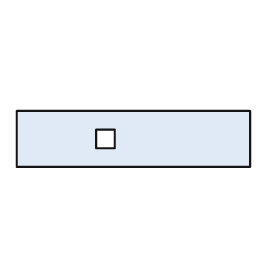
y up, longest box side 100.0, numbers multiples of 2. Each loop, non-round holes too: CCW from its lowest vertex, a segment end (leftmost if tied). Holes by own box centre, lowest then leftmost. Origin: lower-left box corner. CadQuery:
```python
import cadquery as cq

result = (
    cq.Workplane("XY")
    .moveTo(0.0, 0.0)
    .lineTo(100.0, 0.0)
    .lineTo(100.0, 24.0)
    .lineTo(0.0, 24.0)
    .close()
    .moveTo(34.0, 8.0)
    .lineTo(42.0, 8.0)
    .lineTo(42.0, 16.0)
    .lineTo(34.0, 16.0)
    .close()
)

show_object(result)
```